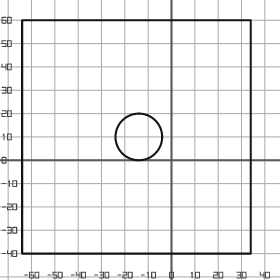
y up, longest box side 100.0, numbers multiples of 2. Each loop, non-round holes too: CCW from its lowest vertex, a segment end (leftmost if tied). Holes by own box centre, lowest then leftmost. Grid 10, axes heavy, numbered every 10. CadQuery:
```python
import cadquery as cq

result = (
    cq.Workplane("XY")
    .moveTo(-64.0, -40.0)
    .lineTo(34.0, -40.0)
    .lineTo(34.0, 60.0)
    .lineTo(-64.0, 60.0)
    .close()
    .moveTo(-14.0, 10.0)
    .circle(10.0)
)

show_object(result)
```